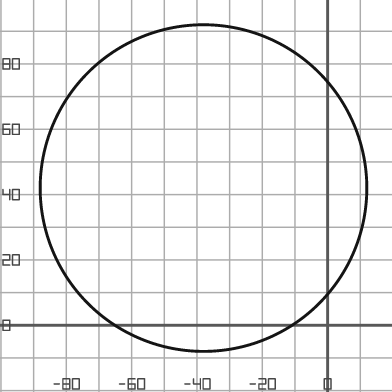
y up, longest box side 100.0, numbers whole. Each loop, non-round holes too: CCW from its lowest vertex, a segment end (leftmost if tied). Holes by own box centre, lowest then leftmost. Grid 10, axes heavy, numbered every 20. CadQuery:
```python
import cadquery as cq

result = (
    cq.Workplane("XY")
    .moveTo(-38.0, 42.0)
    .circle(50.0)
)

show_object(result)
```